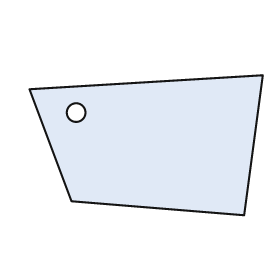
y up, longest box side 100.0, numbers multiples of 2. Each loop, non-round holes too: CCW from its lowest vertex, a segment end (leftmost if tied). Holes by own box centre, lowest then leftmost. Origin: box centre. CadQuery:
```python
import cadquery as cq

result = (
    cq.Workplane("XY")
    .moveTo(42.0, -30.0)
    .lineTo(50.0, 30.0)
    .lineTo(-50.0, 24.0)
    .lineTo(-32.0, -24.0)
    .close()
    .moveTo(-30.0, 14.0)
    .circle(4.0)
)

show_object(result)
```